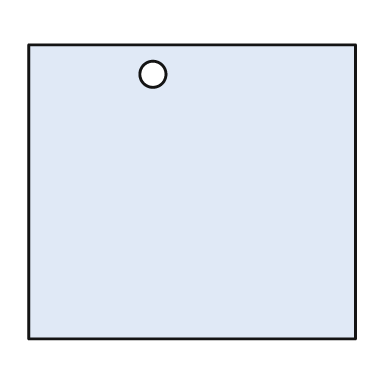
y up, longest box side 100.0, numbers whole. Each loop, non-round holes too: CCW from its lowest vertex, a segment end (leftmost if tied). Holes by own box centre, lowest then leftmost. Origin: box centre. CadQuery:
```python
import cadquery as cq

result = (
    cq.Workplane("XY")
    .moveTo(-50.0, -45.0)
    .lineTo(50.0, -45.0)
    .lineTo(50.0, 45.0)
    .lineTo(-50.0, 45.0)
    .close()
    .moveTo(-12.0, 36.0)
    .circle(4.0)
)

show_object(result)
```